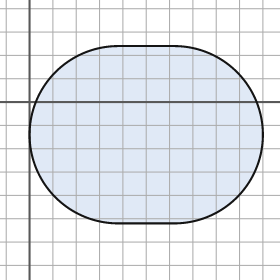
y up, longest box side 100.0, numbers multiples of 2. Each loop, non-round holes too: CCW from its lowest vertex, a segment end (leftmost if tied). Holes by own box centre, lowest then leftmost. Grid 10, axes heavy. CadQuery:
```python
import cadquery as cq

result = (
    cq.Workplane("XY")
    .moveTo(38.0, -52.0)
    .lineTo(62.0, -52.0)
    .threePointArc((100.0, -14.0), (62.0, 24.0))
    .lineTo(38.0, 24.0)
    .threePointArc((0.0, -14.0), (38.0, -52.0))
    .close()
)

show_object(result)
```